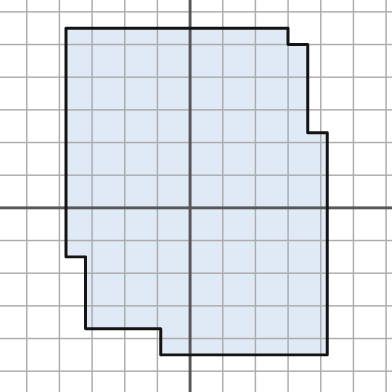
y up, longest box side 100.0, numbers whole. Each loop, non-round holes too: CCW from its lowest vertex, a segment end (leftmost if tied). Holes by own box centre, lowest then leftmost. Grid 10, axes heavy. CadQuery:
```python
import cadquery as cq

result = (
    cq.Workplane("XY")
    .moveTo(-9.0, -45.0)
    .lineTo(42.0, -45.0)
    .lineTo(42.0, 23.0)
    .lineTo(36.0, 23.0)
    .lineTo(36.0, 50.0)
    .lineTo(30.0, 50.0)
    .lineTo(30.0, 55.0)
    .lineTo(-38.0, 55.0)
    .lineTo(-38.0, -15.0)
    .lineTo(-32.0, -15.0)
    .lineTo(-32.0, -37.0)
    .lineTo(-9.0, -37.0)
    .close()
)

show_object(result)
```